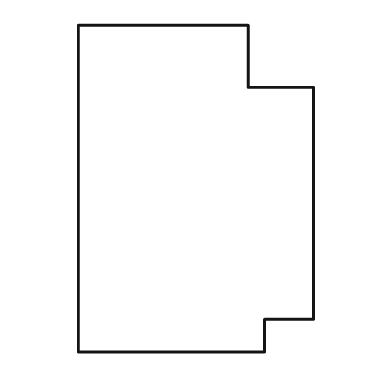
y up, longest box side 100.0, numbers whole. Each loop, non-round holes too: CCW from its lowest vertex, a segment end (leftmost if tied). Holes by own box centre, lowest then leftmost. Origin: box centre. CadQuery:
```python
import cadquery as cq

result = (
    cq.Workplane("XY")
    .moveTo(-36.0, -50.0)
    .lineTo(21.0, -50.0)
    .lineTo(21.0, -40.0)
    .lineTo(36.0, -40.0)
    .lineTo(36.0, 31.0)
    .lineTo(16.0, 31.0)
    .lineTo(16.0, 50.0)
    .lineTo(-36.0, 50.0)
    .close()
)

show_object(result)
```